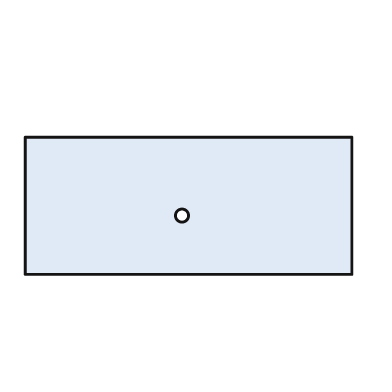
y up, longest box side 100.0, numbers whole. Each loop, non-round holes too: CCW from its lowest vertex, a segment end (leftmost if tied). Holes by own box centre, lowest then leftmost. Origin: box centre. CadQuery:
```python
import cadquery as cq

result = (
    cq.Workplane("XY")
    .moveTo(-50.0, -21.0)
    .lineTo(50.0, -21.0)
    .lineTo(50.0, 21.0)
    .lineTo(-50.0, 21.0)
    .close()
    .moveTo(-2.0, -3.0)
    .circle(2.0)
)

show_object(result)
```